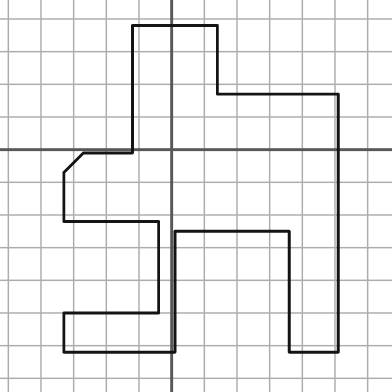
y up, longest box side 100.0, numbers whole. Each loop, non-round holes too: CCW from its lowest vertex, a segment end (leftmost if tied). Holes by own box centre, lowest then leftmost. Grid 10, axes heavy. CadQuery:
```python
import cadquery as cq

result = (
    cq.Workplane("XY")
    .moveTo(-33.0, -62.0)
    .lineTo(1.0, -62.0)
    .lineTo(1.0, -25.0)
    .lineTo(36.0, -25.0)
    .lineTo(36.0, -62.0)
    .lineTo(51.0, -62.0)
    .lineTo(51.0, 17.0)
    .lineTo(14.0, 17.0)
    .lineTo(14.0, 38.0)
    .lineTo(-12.0, 38.0)
    .lineTo(-12.0, -1.0)
    .lineTo(-27.0, -1.0)
    .lineTo(-33.0, -7.0)
    .lineTo(-33.0, -22.0)
    .lineTo(-4.0, -22.0)
    .lineTo(-4.0, -50.0)
    .lineTo(-33.0, -50.0)
    .close()
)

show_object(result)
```